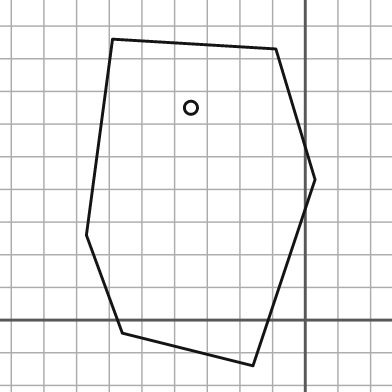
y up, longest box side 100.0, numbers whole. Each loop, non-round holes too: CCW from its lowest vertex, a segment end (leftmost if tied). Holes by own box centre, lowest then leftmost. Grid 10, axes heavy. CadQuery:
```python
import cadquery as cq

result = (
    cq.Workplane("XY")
    .moveTo(-16.0, -14.0)
    .lineTo(3.0, 43.0)
    .lineTo(-9.0, 83.0)
    .lineTo(-59.0, 86.0)
    .lineTo(-67.0, 26.0)
    .lineTo(-56.0, -4.0)
    .close()
    .moveTo(-35.0, 65.0)
    .circle(2.0)
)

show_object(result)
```